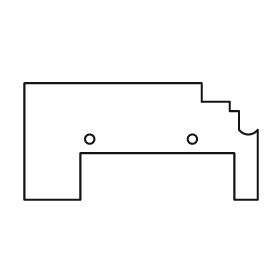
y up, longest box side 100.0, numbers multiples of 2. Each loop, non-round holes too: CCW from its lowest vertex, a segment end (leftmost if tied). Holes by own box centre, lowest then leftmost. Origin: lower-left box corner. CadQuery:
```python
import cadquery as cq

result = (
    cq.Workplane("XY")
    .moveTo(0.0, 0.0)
    .lineTo(24.0, 0.0)
    .lineTo(24.0, 20.0)
    .lineTo(90.0, 20.0)
    .lineTo(90.0, 0.0)
    .lineTo(100.0, 0.0)
    .lineTo(100.0, 30.0)
    .threePointArc((96.0, 28.0), (92.0, 30.0))
    .lineTo(92.0, 38.0)
    .lineTo(88.0, 38.0)
    .lineTo(88.0, 42.0)
    .lineTo(76.0, 42.0)
    .lineTo(76.0, 50.0)
    .lineTo(0.0, 50.0)
    .close()
    .moveTo(28.0, 26.0)
    .circle(2.0)
    .moveTo(72.0, 26.0)
    .circle(2.0)
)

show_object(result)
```